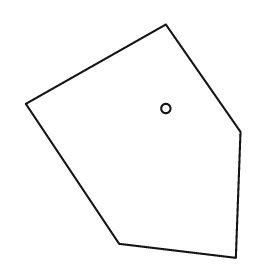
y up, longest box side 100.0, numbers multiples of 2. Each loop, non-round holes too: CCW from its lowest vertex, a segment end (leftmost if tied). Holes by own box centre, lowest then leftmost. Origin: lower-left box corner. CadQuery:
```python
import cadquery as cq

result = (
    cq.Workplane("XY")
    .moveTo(90.0, 0.0)
    .lineTo(92.0, 54.0)
    .lineTo(60.0, 100.0)
    .lineTo(0.0, 66.0)
    .lineTo(40.0, 6.0)
    .close()
    .moveTo(60.0, 64.0)
    .circle(2.0)
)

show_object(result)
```